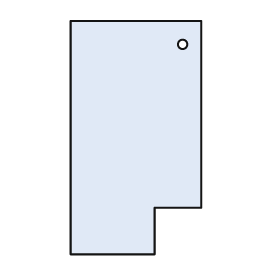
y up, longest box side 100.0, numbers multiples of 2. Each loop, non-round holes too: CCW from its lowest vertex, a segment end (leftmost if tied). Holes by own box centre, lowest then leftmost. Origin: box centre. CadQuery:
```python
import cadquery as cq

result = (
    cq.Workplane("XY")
    .moveTo(-28.0, -50.0)
    .lineTo(8.0, -50.0)
    .lineTo(8.0, -30.0)
    .lineTo(28.0, -30.0)
    .lineTo(28.0, 50.0)
    .lineTo(-28.0, 50.0)
    .close()
    .moveTo(20.0, 40.0)
    .circle(2.0)
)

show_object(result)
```